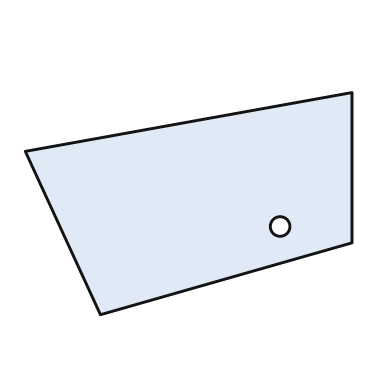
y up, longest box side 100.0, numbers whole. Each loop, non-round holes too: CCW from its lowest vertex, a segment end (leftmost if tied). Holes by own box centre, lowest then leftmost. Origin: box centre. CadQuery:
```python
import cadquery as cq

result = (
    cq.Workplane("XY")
    .moveTo(-27.0, -34.0)
    .lineTo(50.0, -12.0)
    .lineTo(50.0, 34.0)
    .lineTo(-50.0, 16.0)
    .close()
    .moveTo(28.0, -7.0)
    .circle(3.0)
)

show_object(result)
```